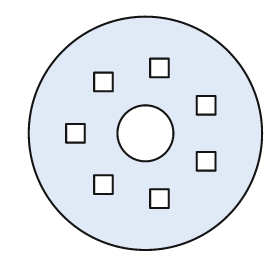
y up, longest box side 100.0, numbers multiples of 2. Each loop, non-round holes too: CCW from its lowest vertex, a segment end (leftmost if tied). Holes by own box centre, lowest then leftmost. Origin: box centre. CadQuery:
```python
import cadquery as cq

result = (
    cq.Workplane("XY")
    .moveTo(0.0, 0.0)
    .circle(50.0)
    .moveTo(2.0, -32.0)
    .lineTo(10.0, -32.0)
    .lineTo(10.0, -24.0)
    .lineTo(2.0, -24.0)
    .close()
    .moveTo(-22.0, -26.0)
    .lineTo(-14.0, -26.0)
    .lineTo(-14.0, -18.0)
    .lineTo(-22.0, -18.0)
    .close()
    .moveTo(22.0, -16.0)
    .lineTo(30.0, -16.0)
    .lineTo(30.0, -8.0)
    .lineTo(22.0, -8.0)
    .close()
    .moveTo(-34.0, -4.0)
    .lineTo(-26.0, -4.0)
    .lineTo(-26.0, 4.0)
    .lineTo(-34.0, 4.0)
    .close()
    .moveTo(0.0, 0.0)
    .circle(12.0)
    .moveTo(22.0, 8.0)
    .lineTo(30.0, 8.0)
    .lineTo(30.0, 16.0)
    .lineTo(22.0, 16.0)
    .close()
    .moveTo(-22.0, 18.0)
    .lineTo(-14.0, 18.0)
    .lineTo(-14.0, 26.0)
    .lineTo(-22.0, 26.0)
    .close()
    .moveTo(2.0, 24.0)
    .lineTo(10.0, 24.0)
    .lineTo(10.0, 32.0)
    .lineTo(2.0, 32.0)
    .close()
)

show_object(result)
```